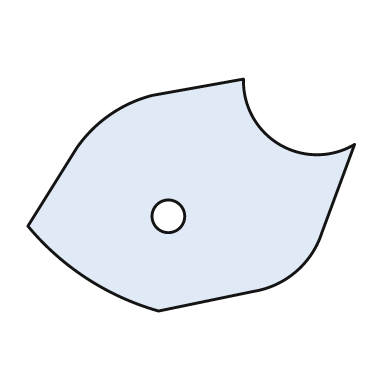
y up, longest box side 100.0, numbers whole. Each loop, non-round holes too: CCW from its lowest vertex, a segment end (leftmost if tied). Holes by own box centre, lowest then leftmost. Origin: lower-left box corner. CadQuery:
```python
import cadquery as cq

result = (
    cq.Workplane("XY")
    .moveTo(40.0, 0.0)
    .lineTo(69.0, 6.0)
    .threePointArc((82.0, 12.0), (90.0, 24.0))
    .lineTo(100.0, 51.0)
    .threePointArc((77.0, 51.0), (66.0, 71.0))
    .lineTo(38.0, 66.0)
    .threePointArc((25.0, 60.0), (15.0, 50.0))
    .lineTo(0.0, 26.0)
    .threePointArc((18.0, 10.0), (40.0, 0.0))
    .close()
    .moveTo(43.0, 29.0)
    .circle(5.0)
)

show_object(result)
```